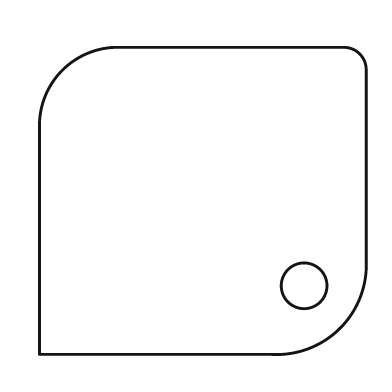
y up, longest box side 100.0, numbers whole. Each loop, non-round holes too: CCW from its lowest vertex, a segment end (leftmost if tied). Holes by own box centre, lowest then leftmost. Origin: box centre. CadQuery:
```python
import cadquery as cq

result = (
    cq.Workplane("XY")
    .moveTo(-50.0, -47.0)
    .lineTo(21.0, -47.0)
    .threePointArc((42.0, -39.0), (50.0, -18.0))
    .lineTo(50.0, 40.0)
    .threePointArc((48.0, 45.0), (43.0, 47.0))
    .lineTo(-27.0, 47.0)
    .threePointArc((-43.0, 40.0), (-50.0, 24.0))
    .close()
    .moveTo(31.0, -26.0)
    .circle(7.0)
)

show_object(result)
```